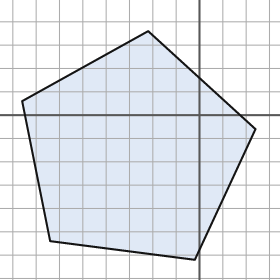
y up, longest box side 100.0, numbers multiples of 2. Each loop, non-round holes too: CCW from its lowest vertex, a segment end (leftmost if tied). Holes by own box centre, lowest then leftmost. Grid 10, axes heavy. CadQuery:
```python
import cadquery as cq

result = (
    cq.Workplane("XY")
    .moveTo(-2.0, -62.0)
    .lineTo(24.0, -6.0)
    .lineTo(-22.0, 36.0)
    .lineTo(-76.0, 6.0)
    .lineTo(-64.0, -54.0)
    .close()
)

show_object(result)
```